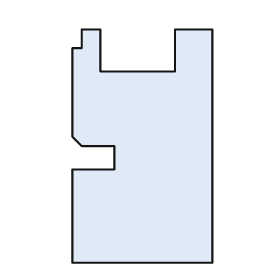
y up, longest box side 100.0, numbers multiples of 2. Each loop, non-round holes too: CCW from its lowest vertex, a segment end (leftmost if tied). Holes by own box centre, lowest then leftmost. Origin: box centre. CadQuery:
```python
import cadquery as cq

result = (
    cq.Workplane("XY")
    .moveTo(-30.0, -50.0)
    .lineTo(30.0, -50.0)
    .lineTo(30.0, 50.0)
    .lineTo(14.0, 50.0)
    .lineTo(14.0, 32.0)
    .lineTo(-18.0, 32.0)
    .lineTo(-18.0, 50.0)
    .lineTo(-26.0, 50.0)
    .lineTo(-26.0, 42.0)
    .lineTo(-30.0, 42.0)
    .lineTo(-30.0, 4.0)
    .lineTo(-26.0, 0.0)
    .lineTo(-12.0, 0.0)
    .lineTo(-12.0, -10.0)
    .lineTo(-30.0, -10.0)
    .close()
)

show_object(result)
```